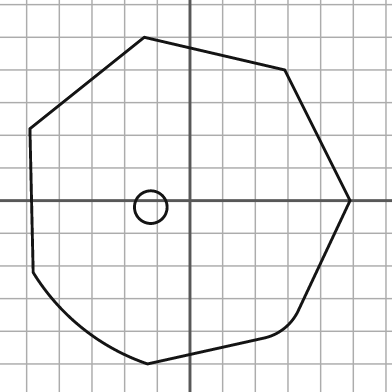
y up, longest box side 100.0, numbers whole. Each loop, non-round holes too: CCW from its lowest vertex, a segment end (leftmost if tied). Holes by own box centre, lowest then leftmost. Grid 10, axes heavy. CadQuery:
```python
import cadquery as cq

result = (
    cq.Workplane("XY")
    .moveTo(-13.0, -50.0)
    .lineTo(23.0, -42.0)
    .threePointArc((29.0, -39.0), (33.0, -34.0))
    .lineTo(49.0, 0.0)
    .lineTo(29.0, 40.0)
    .lineTo(-14.0, 50.0)
    .lineTo(-49.0, 22.0)
    .lineTo(-48.0, -22.0)
    .threePointArc((-33.0, -39.0), (-13.0, -50.0))
    .close()
    .moveTo(-12.0, -2.0)
    .circle(5.0)
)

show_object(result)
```